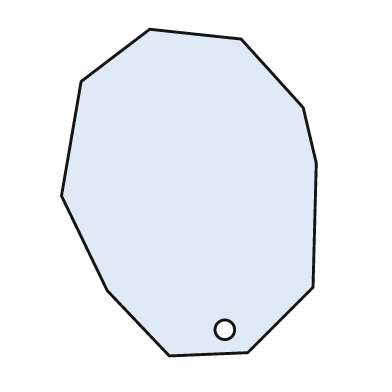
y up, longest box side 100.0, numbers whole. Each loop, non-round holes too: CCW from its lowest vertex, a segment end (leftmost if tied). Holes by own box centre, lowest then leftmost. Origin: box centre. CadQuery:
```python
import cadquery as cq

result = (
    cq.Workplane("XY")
    .moveTo(-6.0, -50.0)
    .lineTo(18.0, -49.0)
    .lineTo(38.0, -29.0)
    .lineTo(39.0, 9.0)
    .lineTo(35.0, 26.0)
    .lineTo(16.0, 47.0)
    .lineTo(-12.0, 50.0)
    .lineTo(-33.0, 34.0)
    .lineTo(-39.0, -1.0)
    .lineTo(-25.0, -30.0)
    .close()
    .moveTo(11.0, -42.0)
    .circle(3.0)
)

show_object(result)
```